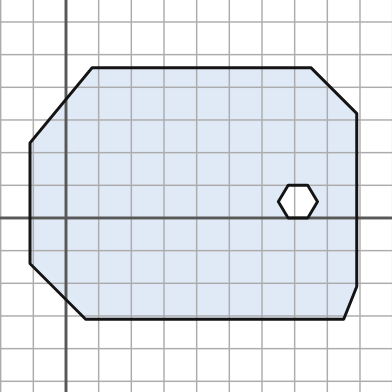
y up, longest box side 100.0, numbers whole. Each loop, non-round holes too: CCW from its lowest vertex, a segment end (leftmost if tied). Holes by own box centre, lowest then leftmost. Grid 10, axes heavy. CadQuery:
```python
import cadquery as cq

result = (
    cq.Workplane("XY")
    .moveTo(6.0, -31.0)
    .lineTo(85.0, -31.0)
    .lineTo(89.0, -21.0)
    .lineTo(89.0, 32.0)
    .lineTo(75.0, 46.0)
    .lineTo(8.0, 46.0)
    .lineTo(-11.0, 23.0)
    .lineTo(-11.0, -14.0)
    .close()
    .moveTo(68.0, 0.0)
    .lineTo(74.0, 0.0)
    .lineTo(77.0, 5.0)
    .lineTo(74.0, 10.0)
    .lineTo(68.0, 10.0)
    .lineTo(65.0, 5.0)
    .close()
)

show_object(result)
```